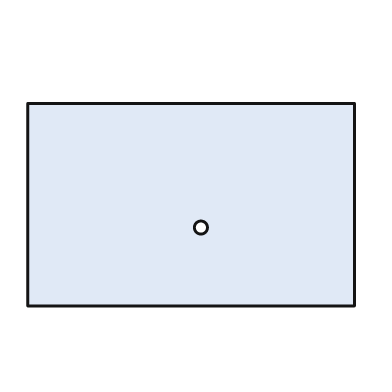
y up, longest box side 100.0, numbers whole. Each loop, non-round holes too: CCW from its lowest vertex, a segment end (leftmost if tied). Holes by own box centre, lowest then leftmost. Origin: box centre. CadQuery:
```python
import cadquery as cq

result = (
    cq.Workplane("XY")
    .moveTo(-50.0, -31.0)
    .lineTo(50.0, -31.0)
    .lineTo(50.0, 31.0)
    .lineTo(-50.0, 31.0)
    .close()
    .moveTo(3.0, -7.0)
    .circle(2.0)
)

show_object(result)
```